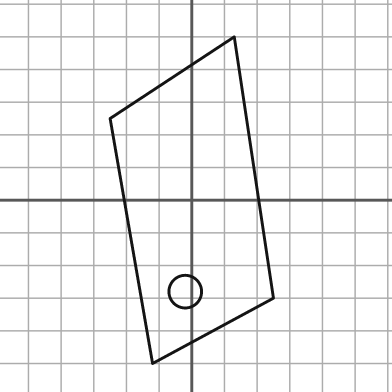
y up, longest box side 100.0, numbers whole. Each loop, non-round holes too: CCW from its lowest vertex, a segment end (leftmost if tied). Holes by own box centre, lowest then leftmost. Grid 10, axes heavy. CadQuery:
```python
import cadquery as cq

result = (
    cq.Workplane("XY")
    .moveTo(-12.0, -50.0)
    .lineTo(25.0, -30.0)
    .lineTo(13.0, 50.0)
    .lineTo(-25.0, 25.0)
    .close()
    .moveTo(-2.0, -28.0)
    .circle(5.0)
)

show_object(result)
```